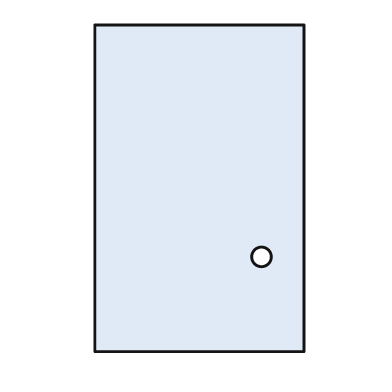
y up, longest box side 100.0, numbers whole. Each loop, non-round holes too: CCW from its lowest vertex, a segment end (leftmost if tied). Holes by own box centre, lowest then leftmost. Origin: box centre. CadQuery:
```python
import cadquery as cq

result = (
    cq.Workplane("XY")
    .moveTo(-32.0, -50.0)
    .lineTo(32.0, -50.0)
    .lineTo(32.0, 50.0)
    .lineTo(-32.0, 50.0)
    .close()
    .moveTo(19.0, -21.0)
    .circle(3.0)
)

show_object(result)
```